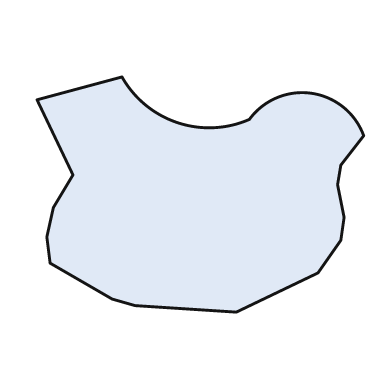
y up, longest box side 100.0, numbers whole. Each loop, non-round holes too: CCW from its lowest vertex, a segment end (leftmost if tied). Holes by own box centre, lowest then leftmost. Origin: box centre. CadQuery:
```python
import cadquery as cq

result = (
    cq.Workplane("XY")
    .moveTo(11.0, -36.0)
    .lineTo(36.0, -24.0)
    .lineTo(43.0, -14.0)
    .lineTo(44.0, -7.0)
    .lineTo(42.0, 3.0)
    .lineTo(43.0, 9.0)
    .lineTo(50.0, 18.0)
    .threePointArc((34.0, 31.0), (15.0, 23.0))
    .threePointArc((-7.0, 22.0), (-24.0, 36.0))
    .lineTo(-50.0, 29.0)
    .lineTo(-39.0, 6.0)
    .lineTo(-45.0, -4.0)
    .lineTo(-47.0, -13.0)
    .lineTo(-46.0, -21.0)
    .lineTo(-27.0, -32.0)
    .lineTo(-20.0, -34.0)
    .close()
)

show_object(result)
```